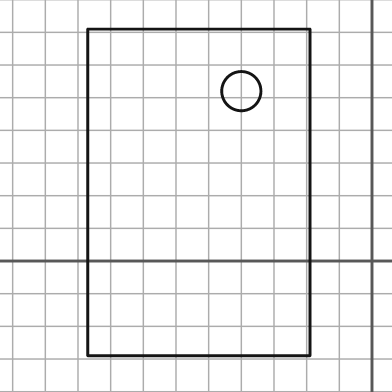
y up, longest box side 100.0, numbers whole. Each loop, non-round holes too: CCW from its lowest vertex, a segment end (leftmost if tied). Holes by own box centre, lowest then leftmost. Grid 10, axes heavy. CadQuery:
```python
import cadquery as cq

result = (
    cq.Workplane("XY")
    .moveTo(-87.0, -29.0)
    .lineTo(-19.0, -29.0)
    .lineTo(-19.0, 71.0)
    .lineTo(-87.0, 71.0)
    .close()
    .moveTo(-40.0, 52.0)
    .circle(6.0)
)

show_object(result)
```